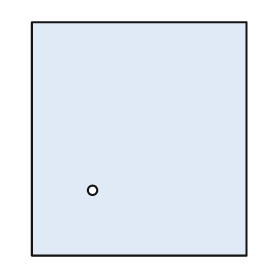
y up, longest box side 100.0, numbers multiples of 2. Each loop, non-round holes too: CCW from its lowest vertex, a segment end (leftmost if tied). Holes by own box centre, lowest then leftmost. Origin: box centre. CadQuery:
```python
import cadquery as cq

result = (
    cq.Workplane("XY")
    .moveTo(-46.0, -50.0)
    .lineTo(46.0, -50.0)
    .lineTo(46.0, 50.0)
    .lineTo(-46.0, 50.0)
    .close()
    .moveTo(-20.0, -22.0)
    .circle(2.0)
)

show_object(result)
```